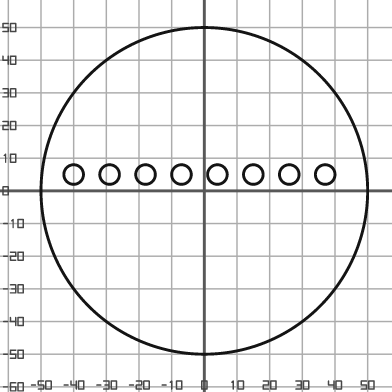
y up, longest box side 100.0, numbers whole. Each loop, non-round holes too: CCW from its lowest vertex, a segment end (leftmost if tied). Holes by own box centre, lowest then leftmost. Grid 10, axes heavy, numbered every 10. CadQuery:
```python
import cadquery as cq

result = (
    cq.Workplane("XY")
    .moveTo(0.0, 0.0)
    .circle(50.0)
    .moveTo(-40.0, 5.0)
    .circle(3.0)
    .moveTo(-29.0, 5.0)
    .circle(3.0)
    .moveTo(-18.0, 5.0)
    .circle(3.0)
    .moveTo(-7.0, 5.0)
    .circle(3.0)
    .moveTo(4.0, 5.0)
    .circle(3.0)
    .moveTo(15.0, 5.0)
    .circle(3.0)
    .moveTo(26.0, 5.0)
    .circle(3.0)
    .moveTo(37.0, 5.0)
    .circle(3.0)
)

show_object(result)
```